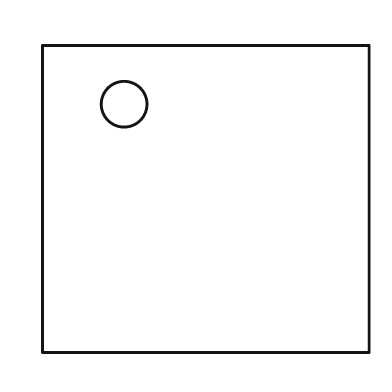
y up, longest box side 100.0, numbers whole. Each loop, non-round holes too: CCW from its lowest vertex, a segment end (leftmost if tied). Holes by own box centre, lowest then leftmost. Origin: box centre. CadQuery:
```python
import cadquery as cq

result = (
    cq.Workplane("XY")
    .moveTo(-50.0, -47.0)
    .lineTo(50.0, -47.0)
    .lineTo(50.0, 47.0)
    .lineTo(-50.0, 47.0)
    .close()
    .moveTo(-25.0, 29.0)
    .circle(7.0)
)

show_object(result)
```